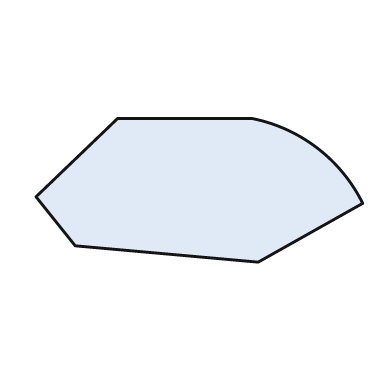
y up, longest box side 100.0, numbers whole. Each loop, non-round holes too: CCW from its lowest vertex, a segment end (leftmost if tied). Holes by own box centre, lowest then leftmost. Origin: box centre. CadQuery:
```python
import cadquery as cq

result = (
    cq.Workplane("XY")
    .moveTo(18.0, -22.0)
    .lineTo(50.0, -4.0)
    .threePointArc((36.0, 13.0), (16.0, 22.0))
    .lineTo(-25.0, 22.0)
    .lineTo(-50.0, -2.0)
    .lineTo(-38.0, -17.0)
    .close()
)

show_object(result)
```